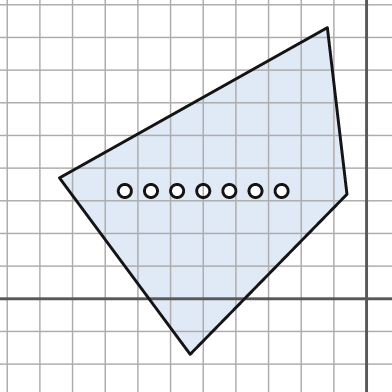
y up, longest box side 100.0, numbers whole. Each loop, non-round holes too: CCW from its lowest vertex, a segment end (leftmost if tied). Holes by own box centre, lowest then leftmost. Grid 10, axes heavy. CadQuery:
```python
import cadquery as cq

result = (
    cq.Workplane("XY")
    .moveTo(-54.0, -17.0)
    .lineTo(-6.0, 32.0)
    .lineTo(-12.0, 83.0)
    .lineTo(-94.0, 37.0)
    .close()
    .moveTo(-74.0, 33.0)
    .circle(2.0)
    .moveTo(-66.0, 33.0)
    .circle(2.0)
    .moveTo(-58.0, 33.0)
    .circle(2.0)
    .moveTo(-50.0, 33.0)
    .circle(2.0)
    .moveTo(-42.0, 33.0)
    .circle(2.0)
    .moveTo(-34.0, 33.0)
    .circle(2.0)
    .moveTo(-26.0, 33.0)
    .circle(2.0)
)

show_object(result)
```